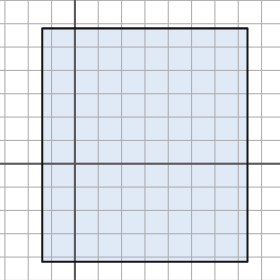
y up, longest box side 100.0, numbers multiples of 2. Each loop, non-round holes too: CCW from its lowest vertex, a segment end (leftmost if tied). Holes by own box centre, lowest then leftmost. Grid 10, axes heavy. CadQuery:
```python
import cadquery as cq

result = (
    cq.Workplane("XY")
    .moveTo(-14.0, -42.0)
    .lineTo(74.0, -42.0)
    .lineTo(74.0, 58.0)
    .lineTo(-14.0, 58.0)
    .close()
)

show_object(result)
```